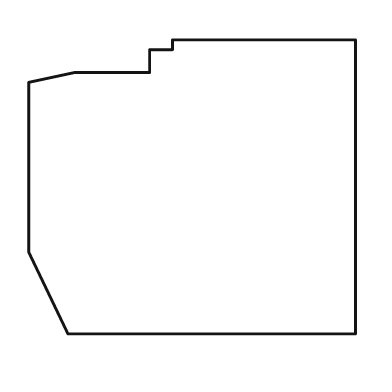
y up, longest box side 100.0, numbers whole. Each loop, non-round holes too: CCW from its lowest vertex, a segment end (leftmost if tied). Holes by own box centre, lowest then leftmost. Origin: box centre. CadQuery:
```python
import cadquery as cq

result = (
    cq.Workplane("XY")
    .moveTo(-38.0, -45.0)
    .lineTo(50.0, -45.0)
    .lineTo(50.0, 45.0)
    .lineTo(-6.0, 45.0)
    .lineTo(-6.0, 42.0)
    .lineTo(-13.0, 42.0)
    .lineTo(-13.0, 35.0)
    .lineTo(-36.0, 35.0)
    .lineTo(-50.0, 32.0)
    .lineTo(-50.0, -20.0)
    .close()
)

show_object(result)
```